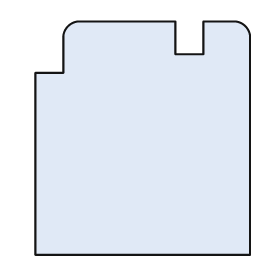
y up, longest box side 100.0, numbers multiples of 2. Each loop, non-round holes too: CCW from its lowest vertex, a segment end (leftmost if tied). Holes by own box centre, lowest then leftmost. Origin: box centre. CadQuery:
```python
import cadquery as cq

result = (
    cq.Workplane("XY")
    .moveTo(-46.0, -50.0)
    .lineTo(46.0, -50.0)
    .lineTo(46.0, 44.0)
    .threePointArc((44.0, 48.0), (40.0, 50.0))
    .lineTo(26.0, 50.0)
    .lineTo(26.0, 36.0)
    .lineTo(14.0, 36.0)
    .lineTo(14.0, 50.0)
    .lineTo(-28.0, 50.0)
    .threePointArc((-32.0, 48.0), (-34.0, 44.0))
    .lineTo(-34.0, 28.0)
    .lineTo(-46.0, 28.0)
    .close()
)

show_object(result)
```